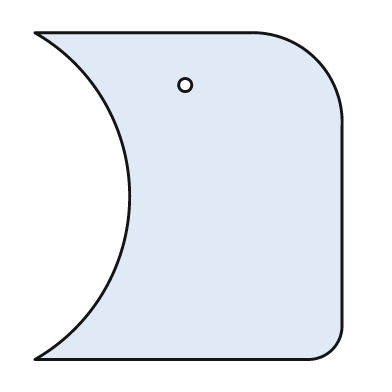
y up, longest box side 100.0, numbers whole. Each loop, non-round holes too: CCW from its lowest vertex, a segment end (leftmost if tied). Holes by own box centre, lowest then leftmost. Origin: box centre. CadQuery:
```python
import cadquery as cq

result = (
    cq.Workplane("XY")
    .moveTo(-47.0, -50.0)
    .lineTo(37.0, -50.0)
    .threePointArc((44.0, -47.0), (47.0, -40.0))
    .lineTo(47.0, 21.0)
    .threePointArc((39.0, 42.0), (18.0, 50.0))
    .lineTo(-47.0, 50.0)
    .threePointArc((-18.0, 0.0), (-47.0, -50.0))
    .close()
    .moveTo(-1.0, 34.0)
    .circle(2.0)
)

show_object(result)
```